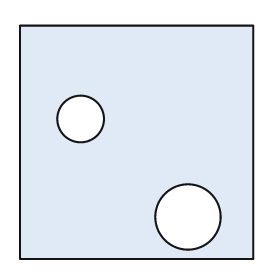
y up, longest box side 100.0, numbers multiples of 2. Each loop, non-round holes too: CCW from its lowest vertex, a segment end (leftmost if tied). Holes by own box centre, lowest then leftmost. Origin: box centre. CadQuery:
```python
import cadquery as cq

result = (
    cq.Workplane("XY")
    .moveTo(-50.0, -50.0)
    .lineTo(50.0, -50.0)
    .lineTo(50.0, 50.0)
    .lineTo(-50.0, 50.0)
    .close()
    .moveTo(22.0, -32.0)
    .circle(14.0)
    .moveTo(-24.0, 10.0)
    .circle(10.0)
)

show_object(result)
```